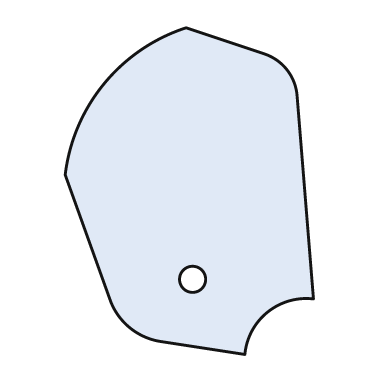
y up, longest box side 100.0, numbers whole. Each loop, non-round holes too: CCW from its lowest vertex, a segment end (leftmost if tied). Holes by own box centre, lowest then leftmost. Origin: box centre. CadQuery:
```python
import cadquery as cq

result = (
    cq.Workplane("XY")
    .moveTo(17.0, -50.0)
    .threePointArc((24.0, -37.0), (38.0, -33.0))
    .lineTo(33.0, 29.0)
    .threePointArc((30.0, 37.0), (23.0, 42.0))
    .lineTo(-1.0, 50.0)
    .threePointArc((-26.0, 33.0), (-38.0, 5.0))
    .lineTo(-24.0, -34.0)
    .threePointArc((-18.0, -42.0), (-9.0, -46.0))
    .close()
    .moveTo(1.0, -27.0)
    .circle(4.0)
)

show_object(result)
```